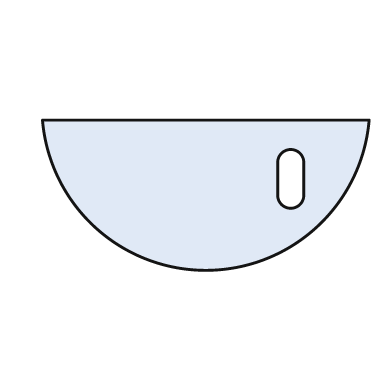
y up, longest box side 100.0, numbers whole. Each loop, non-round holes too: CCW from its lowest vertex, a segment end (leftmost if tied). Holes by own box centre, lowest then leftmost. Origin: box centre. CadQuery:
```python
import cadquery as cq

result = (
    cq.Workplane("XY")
    .moveTo(-50.0, 23.0)
    .threePointArc((0.0, -23.0), (50.0, 23.0))
    .close()
    .moveTo(22.0, 0.0)
    .threePointArc((26.0, -4.0), (30.0, 0.0))
    .lineTo(30.0, 10.0)
    .threePointArc((26.0, 14.0), (22.0, 10.0))
    .close()
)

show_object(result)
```